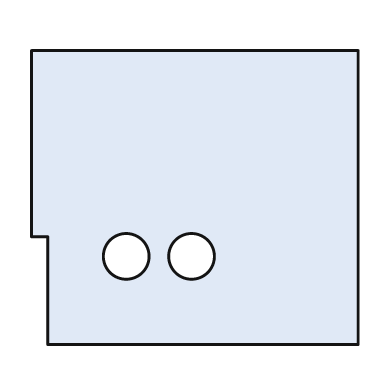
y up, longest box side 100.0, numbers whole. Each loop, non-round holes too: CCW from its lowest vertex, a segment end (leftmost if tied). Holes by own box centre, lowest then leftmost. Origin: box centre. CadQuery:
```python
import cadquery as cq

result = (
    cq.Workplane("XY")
    .moveTo(-45.0, -45.0)
    .lineTo(50.0, -45.0)
    .lineTo(50.0, 45.0)
    .lineTo(-50.0, 45.0)
    .lineTo(-50.0, -12.0)
    .lineTo(-45.0, -12.0)
    .close()
    .moveTo(-21.0, -18.0)
    .circle(7.0)
    .moveTo(-1.0, -18.0)
    .circle(7.0)
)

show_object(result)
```